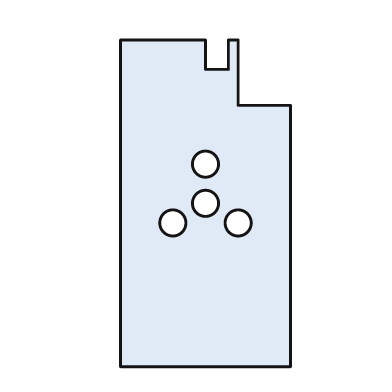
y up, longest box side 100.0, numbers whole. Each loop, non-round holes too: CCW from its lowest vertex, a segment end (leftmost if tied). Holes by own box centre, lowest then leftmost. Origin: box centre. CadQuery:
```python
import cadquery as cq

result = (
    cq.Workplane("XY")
    .moveTo(-26.0, -50.0)
    .lineTo(26.0, -50.0)
    .lineTo(26.0, 30.0)
    .lineTo(10.0, 30.0)
    .lineTo(10.0, 50.0)
    .lineTo(7.0, 50.0)
    .lineTo(7.0, 41.0)
    .lineTo(0.0, 41.0)
    .lineTo(0.0, 50.0)
    .lineTo(-26.0, 50.0)
    .close()
    .moveTo(-10.0, -6.0)
    .circle(4.0)
    .moveTo(10.0, -6.0)
    .circle(4.0)
    .moveTo(0.0, 0.0)
    .circle(4.0)
    .moveTo(0.0, 12.0)
    .circle(4.0)
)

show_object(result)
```